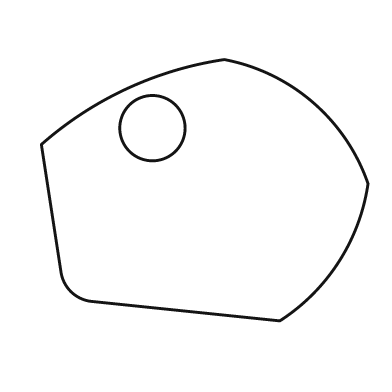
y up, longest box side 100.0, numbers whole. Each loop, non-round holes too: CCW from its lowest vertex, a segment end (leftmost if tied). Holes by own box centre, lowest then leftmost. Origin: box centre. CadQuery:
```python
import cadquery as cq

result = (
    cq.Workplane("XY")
    .moveTo(23.0, -40.0)
    .threePointArc((41.0, -22.0), (50.0, 2.0))
    .threePointArc((33.0, 27.0), (6.0, 40.0))
    .threePointArc((-24.0, 31.0), (-50.0, 14.0))
    .lineTo(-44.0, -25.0)
    .threePointArc((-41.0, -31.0), (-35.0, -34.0))
    .close()
    .moveTo(-16.0, 19.0)
    .circle(10.0)
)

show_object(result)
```